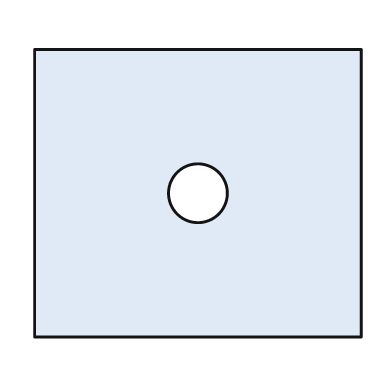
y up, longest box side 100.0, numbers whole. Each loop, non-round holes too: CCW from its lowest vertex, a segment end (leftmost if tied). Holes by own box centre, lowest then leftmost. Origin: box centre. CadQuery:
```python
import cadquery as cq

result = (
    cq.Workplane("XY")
    .moveTo(-50.0, -44.0)
    .lineTo(50.0, -44.0)
    .lineTo(50.0, 44.0)
    .lineTo(-50.0, 44.0)
    .close()
    .moveTo(0.0, 0.0)
    .circle(9.0)
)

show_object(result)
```